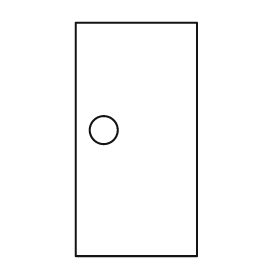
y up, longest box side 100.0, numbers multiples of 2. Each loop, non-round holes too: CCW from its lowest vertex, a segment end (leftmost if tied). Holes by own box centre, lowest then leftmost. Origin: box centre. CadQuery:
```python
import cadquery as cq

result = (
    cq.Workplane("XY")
    .moveTo(-26.0, -50.0)
    .lineTo(26.0, -50.0)
    .lineTo(26.0, 50.0)
    .lineTo(-26.0, 50.0)
    .close()
    .moveTo(-14.0, 4.0)
    .circle(6.0)
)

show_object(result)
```